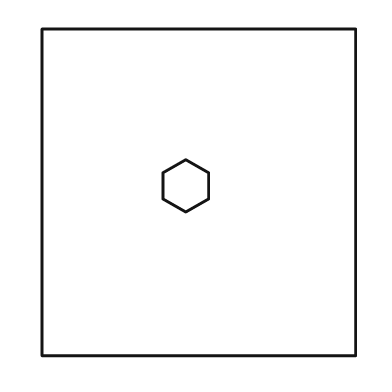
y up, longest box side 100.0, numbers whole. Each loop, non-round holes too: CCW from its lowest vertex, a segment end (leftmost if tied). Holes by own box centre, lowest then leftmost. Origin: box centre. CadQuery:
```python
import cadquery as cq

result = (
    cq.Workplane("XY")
    .moveTo(-48.0, -50.0)
    .lineTo(48.0, -50.0)
    .lineTo(48.0, 50.0)
    .lineTo(-48.0, 50.0)
    .close()
    .moveTo(-4.0, -6.0)
    .lineTo(3.0, -2.0)
    .lineTo(3.0, 6.0)
    .lineTo(-4.0, 10.0)
    .lineTo(-11.0, 6.0)
    .lineTo(-11.0, -2.0)
    .close()
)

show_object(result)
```